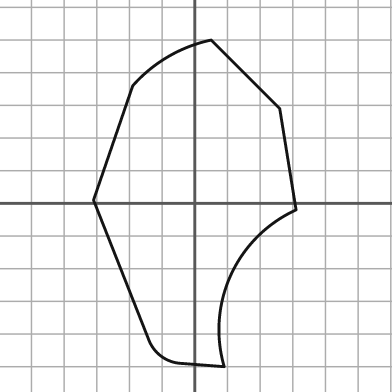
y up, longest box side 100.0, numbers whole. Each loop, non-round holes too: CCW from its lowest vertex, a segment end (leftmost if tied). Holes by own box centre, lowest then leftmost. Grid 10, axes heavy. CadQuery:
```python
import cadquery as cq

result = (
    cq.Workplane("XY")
    .moveTo(9.0, -50.0)
    .threePointArc((11.0, -22.0), (31.0, -2.0))
    .lineTo(26.0, 29.0)
    .lineTo(5.0, 50.0)
    .threePointArc((-8.0, 45.0), (-19.0, 36.0))
    .lineTo(-31.0, 1.0)
    .lineTo(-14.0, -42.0)
    .threePointArc((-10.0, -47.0), (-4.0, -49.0))
    .close()
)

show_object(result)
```